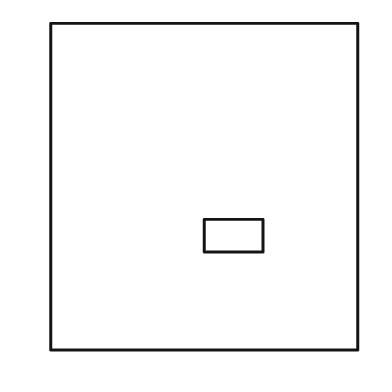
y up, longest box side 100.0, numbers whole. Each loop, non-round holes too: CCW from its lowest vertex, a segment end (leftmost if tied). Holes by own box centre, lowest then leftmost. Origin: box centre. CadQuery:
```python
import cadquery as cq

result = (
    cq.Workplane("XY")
    .moveTo(-47.0, -50.0)
    .lineTo(47.0, -50.0)
    .lineTo(47.0, 50.0)
    .lineTo(-47.0, 50.0)
    .close()
    .moveTo(0.0, -20.0)
    .lineTo(18.0, -20.0)
    .lineTo(18.0, -10.0)
    .lineTo(0.0, -10.0)
    .close()
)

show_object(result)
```